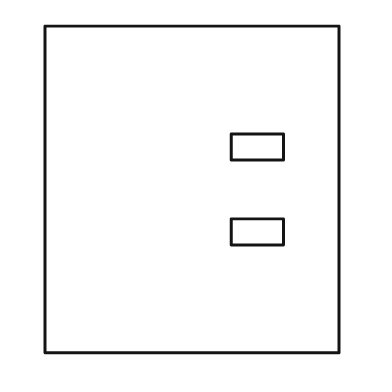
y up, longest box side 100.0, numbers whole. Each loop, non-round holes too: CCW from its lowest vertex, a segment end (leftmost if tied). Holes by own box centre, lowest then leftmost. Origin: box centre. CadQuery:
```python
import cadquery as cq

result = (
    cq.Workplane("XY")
    .moveTo(-45.0, -50.0)
    .lineTo(45.0, -50.0)
    .lineTo(45.0, 50.0)
    .lineTo(-45.0, 50.0)
    .close()
    .moveTo(12.0, -17.0)
    .lineTo(28.0, -17.0)
    .lineTo(28.0, -9.0)
    .lineTo(12.0, -9.0)
    .close()
    .moveTo(12.0, 9.0)
    .lineTo(28.0, 9.0)
    .lineTo(28.0, 17.0)
    .lineTo(12.0, 17.0)
    .close()
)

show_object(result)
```